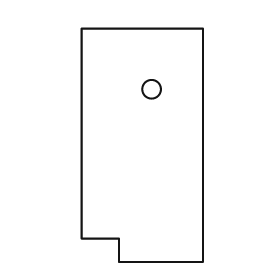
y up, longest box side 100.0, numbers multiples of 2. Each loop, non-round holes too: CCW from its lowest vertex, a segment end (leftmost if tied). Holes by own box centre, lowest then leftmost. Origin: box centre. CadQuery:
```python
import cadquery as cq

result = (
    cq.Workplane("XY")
    .moveTo(-10.0, -50.0)
    .lineTo(26.0, -50.0)
    .lineTo(26.0, 50.0)
    .lineTo(-26.0, 50.0)
    .lineTo(-26.0, -40.0)
    .lineTo(-10.0, -40.0)
    .close()
    .moveTo(4.0, 24.0)
    .circle(4.0)
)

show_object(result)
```